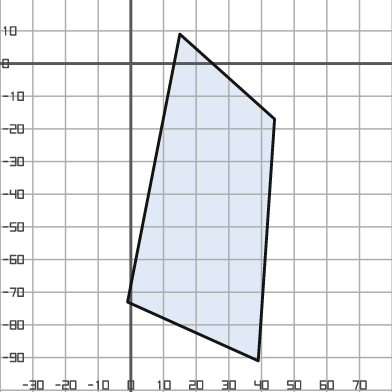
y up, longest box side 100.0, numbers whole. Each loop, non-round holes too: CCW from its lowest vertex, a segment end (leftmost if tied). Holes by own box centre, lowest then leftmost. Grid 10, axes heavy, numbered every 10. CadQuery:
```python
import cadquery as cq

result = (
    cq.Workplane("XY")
    .moveTo(39.0, -91.0)
    .lineTo(44.0, -17.0)
    .lineTo(15.0, 9.0)
    .lineTo(-1.0, -73.0)
    .close()
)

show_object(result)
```